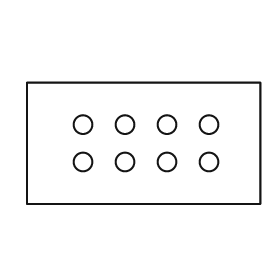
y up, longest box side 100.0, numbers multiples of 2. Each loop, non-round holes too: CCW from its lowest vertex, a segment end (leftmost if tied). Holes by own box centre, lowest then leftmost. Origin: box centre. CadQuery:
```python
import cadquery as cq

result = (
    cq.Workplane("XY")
    .moveTo(-50.0, -26.0)
    .lineTo(50.0, -26.0)
    .lineTo(50.0, 26.0)
    .lineTo(-50.0, 26.0)
    .close()
    .moveTo(-26.0, -8.0)
    .circle(4.0)
    .moveTo(-8.0, -8.0)
    .circle(4.0)
    .moveTo(10.0, -8.0)
    .circle(4.0)
    .moveTo(28.0, -8.0)
    .circle(4.0)
    .moveTo(-26.0, 8.0)
    .circle(4.0)
    .moveTo(-8.0, 8.0)
    .circle(4.0)
    .moveTo(10.0, 8.0)
    .circle(4.0)
    .moveTo(28.0, 8.0)
    .circle(4.0)
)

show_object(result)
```